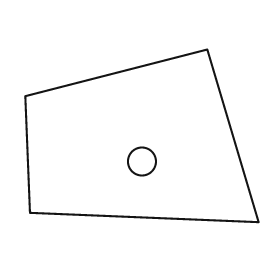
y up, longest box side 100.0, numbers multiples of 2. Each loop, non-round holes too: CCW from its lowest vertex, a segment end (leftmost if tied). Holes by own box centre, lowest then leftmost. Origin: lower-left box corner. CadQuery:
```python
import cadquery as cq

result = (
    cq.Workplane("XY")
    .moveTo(100.0, 0.0)
    .lineTo(78.0, 74.0)
    .lineTo(0.0, 54.0)
    .lineTo(2.0, 4.0)
    .close()
    .moveTo(50.0, 26.0)
    .circle(6.0)
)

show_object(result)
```